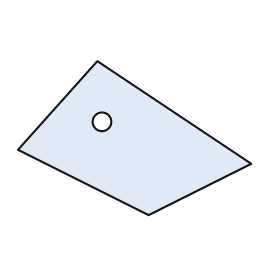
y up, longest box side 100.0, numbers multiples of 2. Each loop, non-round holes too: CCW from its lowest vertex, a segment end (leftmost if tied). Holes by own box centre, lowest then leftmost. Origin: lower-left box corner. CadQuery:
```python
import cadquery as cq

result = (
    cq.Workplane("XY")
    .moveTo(56.0, 0.0)
    .lineTo(100.0, 22.0)
    .lineTo(34.0, 66.0)
    .lineTo(0.0, 28.0)
    .close()
    .moveTo(36.0, 40.0)
    .circle(4.0)
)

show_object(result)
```